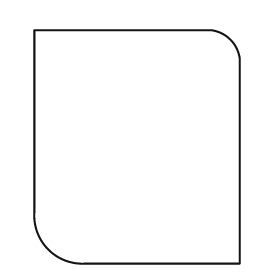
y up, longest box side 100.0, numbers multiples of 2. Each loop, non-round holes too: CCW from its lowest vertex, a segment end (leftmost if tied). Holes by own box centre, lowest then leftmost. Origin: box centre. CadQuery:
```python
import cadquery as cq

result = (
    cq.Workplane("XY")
    .moveTo(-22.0, -50.0)
    .lineTo(44.0, -50.0)
    .lineTo(44.0, 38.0)
    .threePointArc((40.0, 46.0), (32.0, 50.0))
    .lineTo(-44.0, 50.0)
    .lineTo(-44.0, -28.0)
    .threePointArc((-38.0, -44.0), (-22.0, -50.0))
    .close()
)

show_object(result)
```